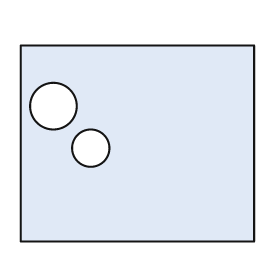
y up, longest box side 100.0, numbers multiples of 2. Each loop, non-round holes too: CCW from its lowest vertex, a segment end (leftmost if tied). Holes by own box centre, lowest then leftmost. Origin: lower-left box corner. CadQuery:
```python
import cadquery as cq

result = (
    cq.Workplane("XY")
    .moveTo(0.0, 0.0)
    .lineTo(100.0, 0.0)
    .lineTo(100.0, 84.0)
    .lineTo(0.0, 84.0)
    .close()
    .moveTo(30.0, 40.0)
    .circle(8.0)
    .moveTo(14.0, 58.0)
    .circle(10.0)
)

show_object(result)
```